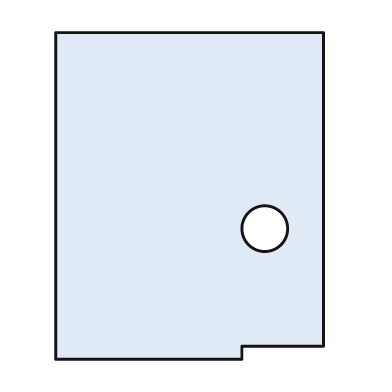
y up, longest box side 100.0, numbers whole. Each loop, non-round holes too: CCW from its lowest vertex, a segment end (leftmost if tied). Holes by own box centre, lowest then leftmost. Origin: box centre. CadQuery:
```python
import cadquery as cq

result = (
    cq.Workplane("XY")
    .moveTo(-41.0, -50.0)
    .lineTo(16.0, -50.0)
    .lineTo(16.0, -46.0)
    .lineTo(41.0, -46.0)
    .lineTo(41.0, 50.0)
    .lineTo(-41.0, 50.0)
    .close()
    .moveTo(23.0, -10.0)
    .circle(7.0)
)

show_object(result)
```